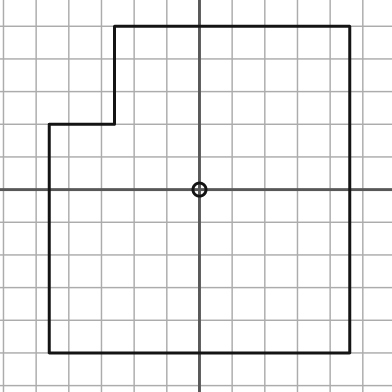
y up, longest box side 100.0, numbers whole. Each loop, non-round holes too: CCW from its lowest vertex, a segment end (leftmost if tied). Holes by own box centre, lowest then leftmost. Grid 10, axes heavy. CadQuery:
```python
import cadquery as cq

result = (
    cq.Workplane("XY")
    .moveTo(-46.0, -50.0)
    .lineTo(46.0, -50.0)
    .lineTo(46.0, 50.0)
    .lineTo(-26.0, 50.0)
    .lineTo(-26.0, 20.0)
    .lineTo(-46.0, 20.0)
    .close()
    .moveTo(0.0, 0.0)
    .circle(2.0)
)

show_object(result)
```